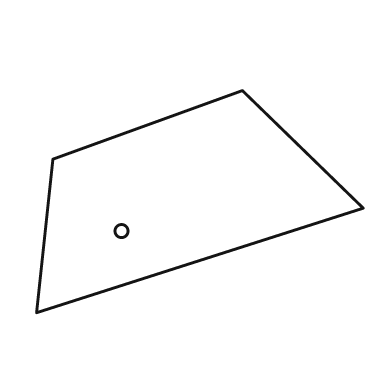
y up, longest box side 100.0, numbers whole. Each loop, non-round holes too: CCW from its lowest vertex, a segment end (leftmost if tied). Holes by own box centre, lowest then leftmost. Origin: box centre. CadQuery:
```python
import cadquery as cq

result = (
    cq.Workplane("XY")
    .moveTo(-50.0, -34.0)
    .lineTo(50.0, -2.0)
    .lineTo(13.0, 34.0)
    .lineTo(-45.0, 13.0)
    .close()
    .moveTo(-24.0, -9.0)
    .circle(2.0)
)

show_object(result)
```